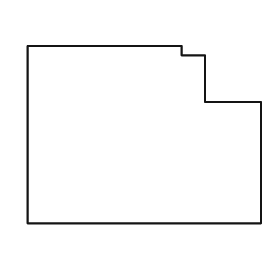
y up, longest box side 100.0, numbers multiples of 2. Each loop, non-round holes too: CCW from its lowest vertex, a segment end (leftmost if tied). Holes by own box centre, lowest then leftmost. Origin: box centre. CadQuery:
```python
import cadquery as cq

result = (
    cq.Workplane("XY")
    .moveTo(-50.0, -38.0)
    .lineTo(50.0, -38.0)
    .lineTo(50.0, 14.0)
    .lineTo(26.0, 14.0)
    .lineTo(26.0, 34.0)
    .lineTo(16.0, 34.0)
    .lineTo(16.0, 38.0)
    .lineTo(-50.0, 38.0)
    .close()
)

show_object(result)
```